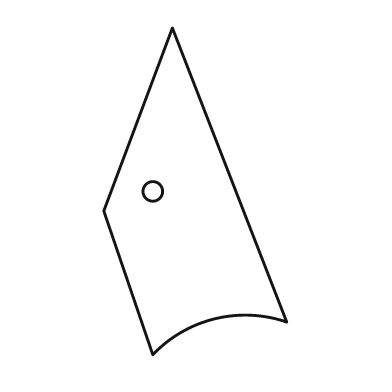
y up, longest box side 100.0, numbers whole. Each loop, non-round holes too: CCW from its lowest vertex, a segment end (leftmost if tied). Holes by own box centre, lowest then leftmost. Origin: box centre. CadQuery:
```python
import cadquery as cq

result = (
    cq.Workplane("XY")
    .moveTo(-13.0, -50.0)
    .threePointArc((6.0, -39.0), (28.0, -40.0))
    .lineTo(-7.0, 50.0)
    .lineTo(-28.0, -6.0)
    .close()
    .moveTo(-13.0, 0.0)
    .circle(3.0)
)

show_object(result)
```